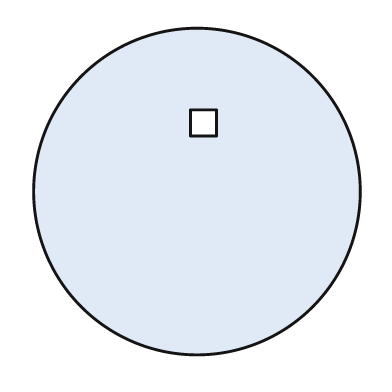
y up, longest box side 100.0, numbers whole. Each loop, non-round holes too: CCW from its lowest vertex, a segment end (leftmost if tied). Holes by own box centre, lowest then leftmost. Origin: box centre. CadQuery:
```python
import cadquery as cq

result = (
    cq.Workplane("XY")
    .moveTo(0.0, 0.0)
    .circle(50.0)
    .moveTo(-2.0, 17.0)
    .lineTo(6.0, 17.0)
    .lineTo(6.0, 25.0)
    .lineTo(-2.0, 25.0)
    .close()
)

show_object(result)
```